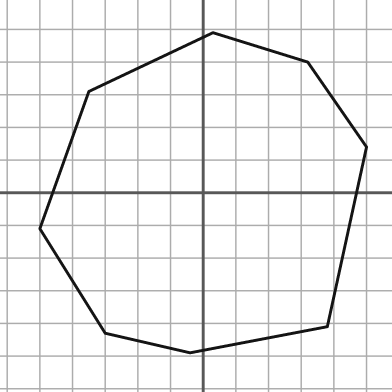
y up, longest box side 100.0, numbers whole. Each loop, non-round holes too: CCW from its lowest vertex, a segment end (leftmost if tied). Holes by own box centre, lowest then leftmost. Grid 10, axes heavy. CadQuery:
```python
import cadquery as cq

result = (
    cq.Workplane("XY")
    .moveTo(-4.0, -49.0)
    .lineTo(38.0, -41.0)
    .lineTo(50.0, 14.0)
    .lineTo(32.0, 40.0)
    .lineTo(3.0, 49.0)
    .lineTo(-35.0, 31.0)
    .lineTo(-50.0, -11.0)
    .lineTo(-30.0, -43.0)
    .close()
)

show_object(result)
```